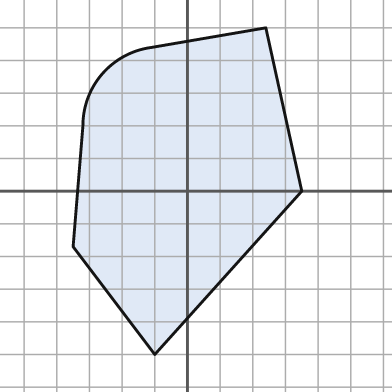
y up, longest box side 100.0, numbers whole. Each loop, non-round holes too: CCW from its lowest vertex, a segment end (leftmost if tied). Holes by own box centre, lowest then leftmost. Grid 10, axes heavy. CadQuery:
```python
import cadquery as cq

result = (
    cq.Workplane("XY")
    .moveTo(-10.0, -50.0)
    .lineTo(35.0, 0.0)
    .lineTo(24.0, 50.0)
    .lineTo(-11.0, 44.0)
    .threePointArc((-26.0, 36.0), (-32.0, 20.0))
    .lineTo(-35.0, -17.0)
    .close()
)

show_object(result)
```